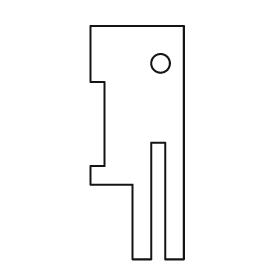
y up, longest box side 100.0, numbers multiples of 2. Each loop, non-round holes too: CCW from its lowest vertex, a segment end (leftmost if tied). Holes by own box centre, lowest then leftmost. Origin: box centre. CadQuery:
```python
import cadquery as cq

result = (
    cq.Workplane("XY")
    .moveTo(-2.0, -50.0)
    .lineTo(6.0, -50.0)
    .lineTo(6.0, 0.0)
    .lineTo(12.0, 0.0)
    .lineTo(12.0, -50.0)
    .lineTo(20.0, -50.0)
    .lineTo(20.0, 50.0)
    .lineTo(-20.0, 50.0)
    .lineTo(-20.0, 26.0)
    .lineTo(-14.0, 26.0)
    .lineTo(-14.0, -10.0)
    .lineTo(-20.0, -10.0)
    .lineTo(-20.0, -18.0)
    .lineTo(-2.0, -18.0)
    .close()
    .moveTo(10.0, 34.0)
    .circle(4.0)
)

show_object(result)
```